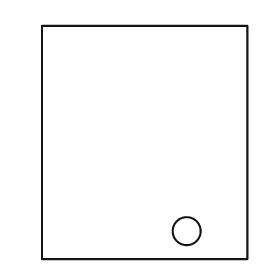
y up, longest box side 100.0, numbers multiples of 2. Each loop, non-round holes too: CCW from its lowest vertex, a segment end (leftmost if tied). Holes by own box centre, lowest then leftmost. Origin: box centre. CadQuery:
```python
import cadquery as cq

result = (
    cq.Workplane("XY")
    .moveTo(-44.0, -50.0)
    .lineTo(44.0, -50.0)
    .lineTo(44.0, 50.0)
    .lineTo(-44.0, 50.0)
    .close()
    .moveTo(18.0, -38.0)
    .circle(6.0)
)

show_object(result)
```